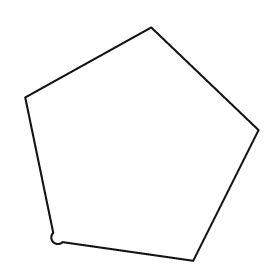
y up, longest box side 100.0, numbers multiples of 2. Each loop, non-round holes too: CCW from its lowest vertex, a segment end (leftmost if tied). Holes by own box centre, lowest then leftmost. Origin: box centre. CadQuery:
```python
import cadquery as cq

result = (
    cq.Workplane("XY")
    .moveTo(22.0, -50.0)
    .lineTo(50.0, 6.0)
    .lineTo(4.0, 50.0)
    .lineTo(-50.0, 20.0)
    .lineTo(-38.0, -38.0)
    .threePointArc((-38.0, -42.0), (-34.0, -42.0))
    .close()
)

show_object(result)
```